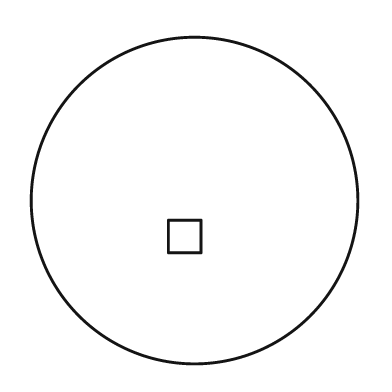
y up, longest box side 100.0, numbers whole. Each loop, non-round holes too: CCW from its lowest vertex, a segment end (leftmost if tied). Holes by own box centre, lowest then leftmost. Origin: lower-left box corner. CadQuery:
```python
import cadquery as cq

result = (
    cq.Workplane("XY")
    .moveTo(50.0, 50.0)
    .circle(50.0)
    .moveTo(42.0, 34.0)
    .lineTo(52.0, 34.0)
    .lineTo(52.0, 44.0)
    .lineTo(42.0, 44.0)
    .close()
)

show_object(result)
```